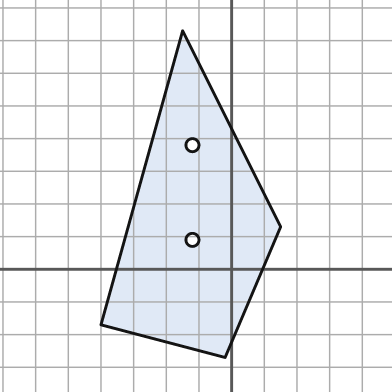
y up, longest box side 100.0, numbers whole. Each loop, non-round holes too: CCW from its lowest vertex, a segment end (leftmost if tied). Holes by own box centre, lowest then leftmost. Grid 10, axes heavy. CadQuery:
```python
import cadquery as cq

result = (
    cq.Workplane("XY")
    .moveTo(-2.0, -27.0)
    .lineTo(15.0, 13.0)
    .lineTo(-15.0, 73.0)
    .lineTo(-40.0, -17.0)
    .close()
    .moveTo(-12.0, 9.0)
    .circle(2.0)
    .moveTo(-12.0, 38.0)
    .circle(2.0)
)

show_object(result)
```